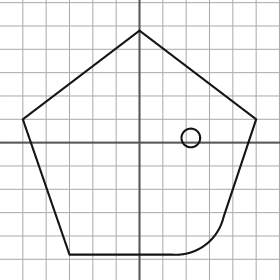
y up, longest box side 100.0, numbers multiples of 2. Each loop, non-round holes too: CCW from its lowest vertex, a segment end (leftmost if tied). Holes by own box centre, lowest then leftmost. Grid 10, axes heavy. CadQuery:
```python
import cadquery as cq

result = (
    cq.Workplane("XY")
    .moveTo(-30.0, -48.0)
    .lineTo(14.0, -48.0)
    .threePointArc((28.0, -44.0), (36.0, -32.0))
    .lineTo(50.0, 10.0)
    .lineTo(0.0, 48.0)
    .lineTo(-50.0, 10.0)
    .close()
    .moveTo(22.0, 2.0)
    .circle(4.0)
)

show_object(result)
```